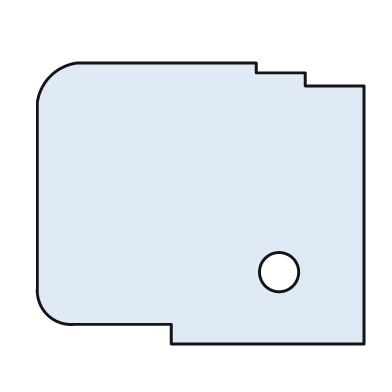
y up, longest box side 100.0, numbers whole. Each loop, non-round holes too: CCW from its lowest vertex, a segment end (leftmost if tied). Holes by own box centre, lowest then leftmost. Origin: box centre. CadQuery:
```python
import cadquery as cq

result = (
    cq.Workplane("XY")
    .moveTo(-9.0, -43.0)
    .lineTo(50.0, -43.0)
    .lineTo(50.0, 36.0)
    .lineTo(32.0, 36.0)
    .lineTo(32.0, 40.0)
    .lineTo(17.0, 40.0)
    .lineTo(17.0, 43.0)
    .lineTo(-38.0, 43.0)
    .threePointArc((-46.0, 39.0), (-50.0, 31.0))
    .lineTo(-50.0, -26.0)
    .threePointArc((-47.0, -34.0), (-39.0, -37.0))
    .lineTo(-9.0, -37.0)
    .close()
    .moveTo(24.0, -21.0)
    .circle(6.0)
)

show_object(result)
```